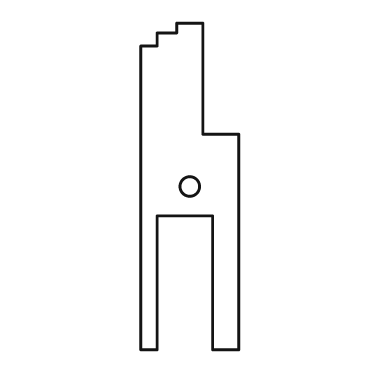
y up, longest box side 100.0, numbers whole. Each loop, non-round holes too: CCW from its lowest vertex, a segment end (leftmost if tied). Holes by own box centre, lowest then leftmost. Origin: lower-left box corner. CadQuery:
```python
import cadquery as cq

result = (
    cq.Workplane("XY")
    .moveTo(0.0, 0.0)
    .lineTo(5.0, 0.0)
    .lineTo(5.0, 41.0)
    .lineTo(22.0, 41.0)
    .lineTo(22.0, 0.0)
    .lineTo(30.0, 0.0)
    .lineTo(30.0, 66.0)
    .lineTo(19.0, 66.0)
    .lineTo(19.0, 100.0)
    .lineTo(11.0, 100.0)
    .lineTo(11.0, 97.0)
    .lineTo(5.0, 97.0)
    .lineTo(5.0, 93.0)
    .lineTo(0.0, 93.0)
    .close()
    .moveTo(15.0, 50.0)
    .circle(3.0)
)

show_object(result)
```